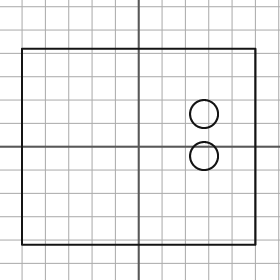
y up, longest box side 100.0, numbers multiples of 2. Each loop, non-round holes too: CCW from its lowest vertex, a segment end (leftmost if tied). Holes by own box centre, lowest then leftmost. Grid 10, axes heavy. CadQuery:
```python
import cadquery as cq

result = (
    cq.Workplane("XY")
    .moveTo(-50.0, -42.0)
    .lineTo(50.0, -42.0)
    .lineTo(50.0, 42.0)
    .lineTo(-50.0, 42.0)
    .close()
    .moveTo(28.0, -4.0)
    .circle(6.0)
    .moveTo(28.0, 14.0)
    .circle(6.0)
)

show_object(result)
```